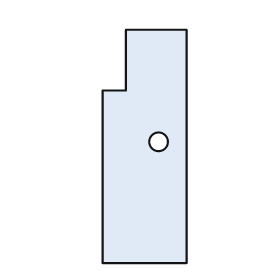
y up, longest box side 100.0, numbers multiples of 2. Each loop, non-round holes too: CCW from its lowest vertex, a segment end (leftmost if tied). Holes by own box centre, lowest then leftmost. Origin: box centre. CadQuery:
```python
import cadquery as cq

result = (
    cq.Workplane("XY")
    .moveTo(-18.0, -50.0)
    .lineTo(18.0, -50.0)
    .lineTo(18.0, 50.0)
    .lineTo(-8.0, 50.0)
    .lineTo(-8.0, 24.0)
    .lineTo(-18.0, 24.0)
    .close()
    .moveTo(6.0, 2.0)
    .circle(4.0)
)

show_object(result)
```